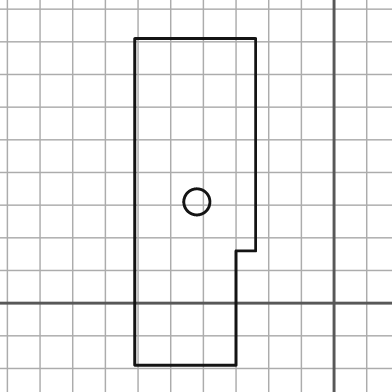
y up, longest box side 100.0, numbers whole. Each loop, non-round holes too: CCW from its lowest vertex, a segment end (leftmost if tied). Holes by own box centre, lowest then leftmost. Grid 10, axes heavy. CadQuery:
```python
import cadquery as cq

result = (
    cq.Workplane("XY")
    .moveTo(-61.0, -19.0)
    .lineTo(-30.0, -19.0)
    .lineTo(-30.0, 16.0)
    .lineTo(-24.0, 16.0)
    .lineTo(-24.0, 81.0)
    .lineTo(-61.0, 81.0)
    .close()
    .moveTo(-42.0, 31.0)
    .circle(4.0)
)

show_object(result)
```